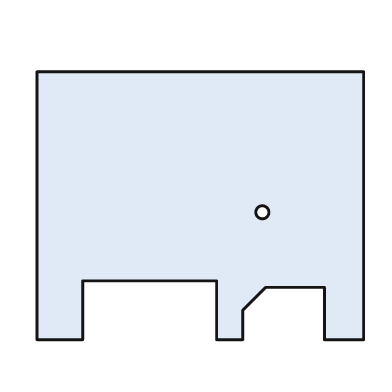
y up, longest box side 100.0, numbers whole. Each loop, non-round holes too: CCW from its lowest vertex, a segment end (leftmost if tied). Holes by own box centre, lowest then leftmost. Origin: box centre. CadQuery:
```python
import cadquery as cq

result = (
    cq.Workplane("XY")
    .moveTo(-50.0, -41.0)
    .lineTo(-36.0, -41.0)
    .lineTo(-36.0, -23.0)
    .lineTo(5.0, -23.0)
    .lineTo(5.0, -41.0)
    .lineTo(13.0, -41.0)
    .lineTo(13.0, -32.0)
    .lineTo(20.0, -25.0)
    .lineTo(38.0, -25.0)
    .lineTo(38.0, -41.0)
    .lineTo(50.0, -41.0)
    .lineTo(50.0, 41.0)
    .lineTo(-50.0, 41.0)
    .close()
    .moveTo(19.0, -2.0)
    .circle(2.0)
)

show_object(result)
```